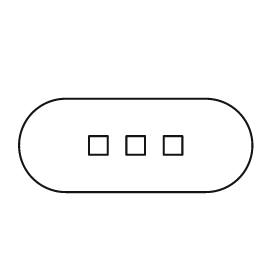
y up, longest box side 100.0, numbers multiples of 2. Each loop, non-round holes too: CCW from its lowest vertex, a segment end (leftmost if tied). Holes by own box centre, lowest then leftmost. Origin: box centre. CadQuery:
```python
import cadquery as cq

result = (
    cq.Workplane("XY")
    .moveTo(-30.0, -20.0)
    .lineTo(30.0, -20.0)
    .threePointArc((50.0, 0.0), (30.0, 20.0))
    .lineTo(-30.0, 20.0)
    .threePointArc((-50.0, 0.0), (-30.0, -20.0))
    .close()
    .moveTo(-20.0, -4.0)
    .lineTo(-12.0, -4.0)
    .lineTo(-12.0, 4.0)
    .lineTo(-20.0, 4.0)
    .close()
    .moveTo(-4.0, -4.0)
    .lineTo(4.0, -4.0)
    .lineTo(4.0, 4.0)
    .lineTo(-4.0, 4.0)
    .close()
    .moveTo(12.0, -4.0)
    .lineTo(20.0, -4.0)
    .lineTo(20.0, 4.0)
    .lineTo(12.0, 4.0)
    .close()
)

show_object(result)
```